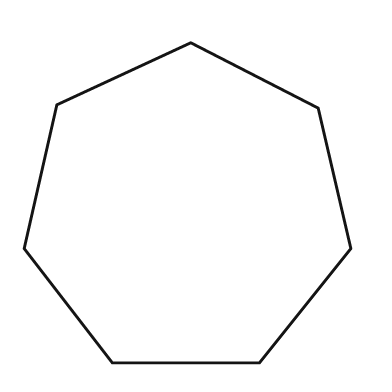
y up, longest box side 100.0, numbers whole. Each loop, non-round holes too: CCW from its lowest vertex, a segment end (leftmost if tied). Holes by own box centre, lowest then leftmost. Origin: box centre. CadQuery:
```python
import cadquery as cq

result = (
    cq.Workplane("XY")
    .moveTo(-23.0, -49.0)
    .lineTo(22.0, -49.0)
    .lineTo(50.0, -14.0)
    .lineTo(40.0, 29.0)
    .lineTo(1.0, 49.0)
    .lineTo(-40.0, 30.0)
    .lineTo(-50.0, -14.0)
    .close()
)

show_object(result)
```